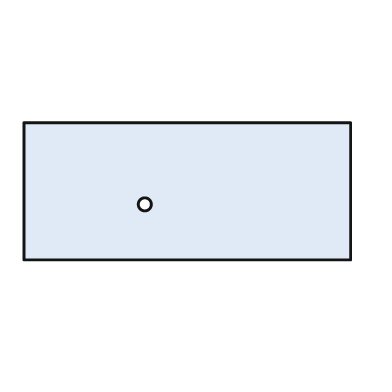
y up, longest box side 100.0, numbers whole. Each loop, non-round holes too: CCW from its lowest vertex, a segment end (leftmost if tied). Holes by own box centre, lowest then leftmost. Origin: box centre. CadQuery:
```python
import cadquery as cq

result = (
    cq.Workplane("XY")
    .moveTo(-50.0, -21.0)
    .lineTo(50.0, -21.0)
    .lineTo(50.0, 21.0)
    .lineTo(-50.0, 21.0)
    .close()
    .moveTo(-13.0, -4.0)
    .circle(2.0)
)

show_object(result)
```